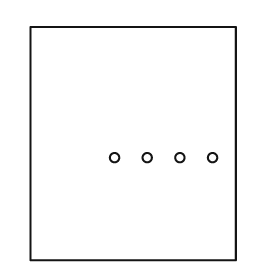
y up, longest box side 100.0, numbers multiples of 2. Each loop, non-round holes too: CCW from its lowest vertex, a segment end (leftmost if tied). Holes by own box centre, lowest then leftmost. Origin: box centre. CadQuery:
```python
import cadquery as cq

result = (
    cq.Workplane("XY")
    .moveTo(-44.0, -50.0)
    .lineTo(44.0, -50.0)
    .lineTo(44.0, 50.0)
    .lineTo(-44.0, 50.0)
    .close()
    .moveTo(-8.0, -6.0)
    .circle(2.0)
    .moveTo(6.0, -6.0)
    .circle(2.0)
    .moveTo(20.0, -6.0)
    .circle(2.0)
    .moveTo(34.0, -6.0)
    .circle(2.0)
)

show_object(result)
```